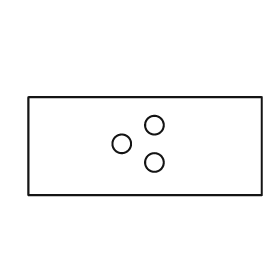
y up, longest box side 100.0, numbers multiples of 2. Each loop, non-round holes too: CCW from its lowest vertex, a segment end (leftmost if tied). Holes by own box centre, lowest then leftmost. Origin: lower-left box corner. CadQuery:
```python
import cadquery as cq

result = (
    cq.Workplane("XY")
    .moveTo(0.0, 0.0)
    .lineTo(100.0, 0.0)
    .lineTo(100.0, 42.0)
    .lineTo(0.0, 42.0)
    .close()
    .moveTo(54.0, 14.0)
    .circle(4.0)
    .moveTo(40.0, 22.0)
    .circle(4.0)
    .moveTo(54.0, 30.0)
    .circle(4.0)
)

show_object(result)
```